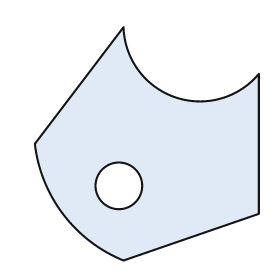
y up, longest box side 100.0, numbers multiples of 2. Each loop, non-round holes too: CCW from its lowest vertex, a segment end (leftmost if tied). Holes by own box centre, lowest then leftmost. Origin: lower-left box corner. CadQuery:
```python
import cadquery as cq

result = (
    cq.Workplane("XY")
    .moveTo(38.0, 0.0)
    .lineTo(96.0, 20.0)
    .lineTo(96.0, 80.0)
    .threePointArc((60.0, 70.0), (38.0, 100.0))
    .lineTo(0.0, 50.0)
    .threePointArc((12.0, 20.0), (38.0, 0.0))
    .close()
    .moveTo(36.0, 32.0)
    .circle(10.0)
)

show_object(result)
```